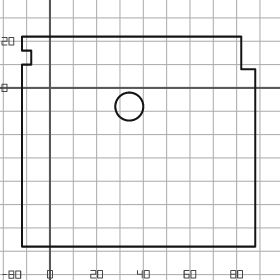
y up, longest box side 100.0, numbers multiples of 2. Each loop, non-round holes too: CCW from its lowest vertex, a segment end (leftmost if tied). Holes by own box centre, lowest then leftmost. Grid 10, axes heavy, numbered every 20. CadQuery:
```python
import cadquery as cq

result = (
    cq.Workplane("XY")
    .moveTo(-12.0, -68.0)
    .lineTo(88.0, -68.0)
    .lineTo(88.0, 8.0)
    .lineTo(82.0, 8.0)
    .lineTo(82.0, 22.0)
    .lineTo(-12.0, 22.0)
    .lineTo(-12.0, 16.0)
    .lineTo(-8.0, 16.0)
    .lineTo(-8.0, 10.0)
    .lineTo(-12.0, 10.0)
    .close()
    .moveTo(34.0, -8.0)
    .circle(6.0)
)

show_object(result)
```